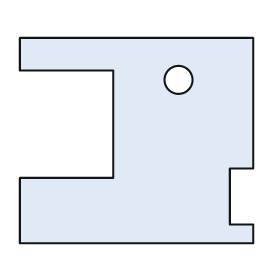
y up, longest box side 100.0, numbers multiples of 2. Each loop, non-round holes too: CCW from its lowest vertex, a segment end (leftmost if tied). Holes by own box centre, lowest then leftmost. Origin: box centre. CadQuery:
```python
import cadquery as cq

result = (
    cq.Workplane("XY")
    .moveTo(-50.0, -44.0)
    .lineTo(50.0, -44.0)
    .lineTo(50.0, -36.0)
    .lineTo(40.0, -36.0)
    .lineTo(40.0, -12.0)
    .lineTo(50.0, -12.0)
    .lineTo(50.0, 44.0)
    .lineTo(-50.0, 44.0)
    .lineTo(-50.0, 30.0)
    .lineTo(-10.0, 30.0)
    .lineTo(-10.0, -16.0)
    .lineTo(-50.0, -16.0)
    .close()
    .moveTo(18.0, 26.0)
    .circle(6.0)
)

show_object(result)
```